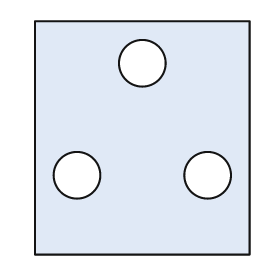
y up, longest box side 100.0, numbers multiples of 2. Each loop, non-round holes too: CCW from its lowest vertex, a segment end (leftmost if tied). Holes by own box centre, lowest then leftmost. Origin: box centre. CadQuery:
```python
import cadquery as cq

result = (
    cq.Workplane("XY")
    .moveTo(-46.0, -50.0)
    .lineTo(46.0, -50.0)
    .lineTo(46.0, 50.0)
    .lineTo(-46.0, 50.0)
    .close()
    .moveTo(-28.0, -16.0)
    .circle(10.0)
    .moveTo(28.0, -16.0)
    .circle(10.0)
    .moveTo(0.0, 32.0)
    .circle(10.0)
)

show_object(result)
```